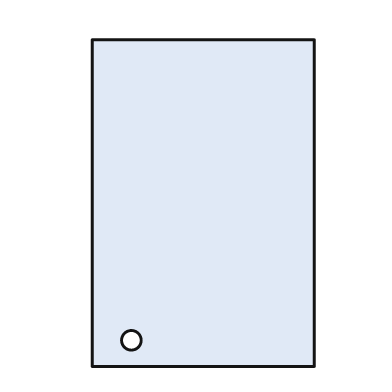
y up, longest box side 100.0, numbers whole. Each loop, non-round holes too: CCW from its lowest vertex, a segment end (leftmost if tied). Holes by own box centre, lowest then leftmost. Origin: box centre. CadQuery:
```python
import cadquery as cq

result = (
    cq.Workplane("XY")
    .moveTo(-34.0, -50.0)
    .lineTo(34.0, -50.0)
    .lineTo(34.0, 50.0)
    .lineTo(-34.0, 50.0)
    .close()
    .moveTo(-22.0, -42.0)
    .circle(3.0)
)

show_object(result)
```